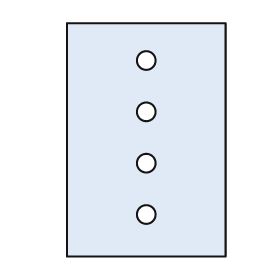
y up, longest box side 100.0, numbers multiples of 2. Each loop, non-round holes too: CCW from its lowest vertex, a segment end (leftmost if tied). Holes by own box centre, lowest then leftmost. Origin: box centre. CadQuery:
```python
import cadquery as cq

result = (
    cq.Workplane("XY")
    .moveTo(-34.0, -50.0)
    .lineTo(34.0, -50.0)
    .lineTo(34.0, 50.0)
    .lineTo(-34.0, 50.0)
    .close()
    .moveTo(0.0, -32.0)
    .circle(4.0)
    .moveTo(0.0, -10.0)
    .circle(4.0)
    .moveTo(0.0, 12.0)
    .circle(4.0)
    .moveTo(0.0, 34.0)
    .circle(4.0)
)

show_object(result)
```